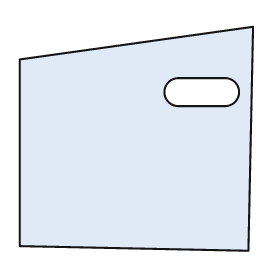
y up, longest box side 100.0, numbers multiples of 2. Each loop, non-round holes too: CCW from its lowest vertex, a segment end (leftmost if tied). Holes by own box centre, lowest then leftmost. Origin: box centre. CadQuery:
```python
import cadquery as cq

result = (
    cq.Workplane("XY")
    .moveTo(48.0, -48.0)
    .lineTo(50.0, 48.0)
    .lineTo(-50.0, 34.0)
    .lineTo(-50.0, -46.0)
    .close()
    .moveTo(18.0, 14.0)
    .lineTo(38.0, 14.0)
    .threePointArc((44.0, 20.0), (38.0, 26.0))
    .lineTo(18.0, 26.0)
    .threePointArc((12.0, 20.0), (18.0, 14.0))
    .close()
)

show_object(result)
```